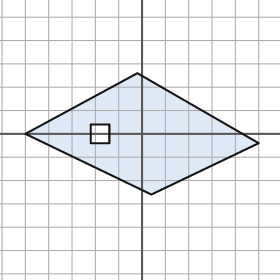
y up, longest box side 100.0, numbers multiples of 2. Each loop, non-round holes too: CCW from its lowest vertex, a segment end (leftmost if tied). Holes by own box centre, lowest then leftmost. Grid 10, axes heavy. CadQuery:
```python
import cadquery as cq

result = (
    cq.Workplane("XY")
    .moveTo(4.0, -26.0)
    .lineTo(50.0, -4.0)
    .lineTo(-2.0, 26.0)
    .lineTo(-50.0, 0.0)
    .close()
    .moveTo(-22.0, -4.0)
    .lineTo(-14.0, -4.0)
    .lineTo(-14.0, 4.0)
    .lineTo(-22.0, 4.0)
    .close()
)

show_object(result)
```